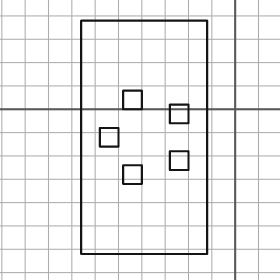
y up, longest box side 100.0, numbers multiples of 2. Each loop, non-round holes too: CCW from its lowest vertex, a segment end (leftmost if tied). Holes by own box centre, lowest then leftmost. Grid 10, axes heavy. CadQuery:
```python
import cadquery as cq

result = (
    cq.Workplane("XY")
    .moveTo(-66.0, -62.0)
    .lineTo(-12.0, -62.0)
    .lineTo(-12.0, 38.0)
    .lineTo(-66.0, 38.0)
    .close()
    .moveTo(-48.0, -32.0)
    .lineTo(-40.0, -32.0)
    .lineTo(-40.0, -24.0)
    .lineTo(-48.0, -24.0)
    .close()
    .moveTo(-28.0, -26.0)
    .lineTo(-20.0, -26.0)
    .lineTo(-20.0, -18.0)
    .lineTo(-28.0, -18.0)
    .close()
    .moveTo(-58.0, -16.0)
    .lineTo(-50.0, -16.0)
    .lineTo(-50.0, -8.0)
    .lineTo(-58.0, -8.0)
    .close()
    .moveTo(-28.0, -6.0)
    .lineTo(-20.0, -6.0)
    .lineTo(-20.0, 2.0)
    .lineTo(-28.0, 2.0)
    .close()
    .moveTo(-48.0, 0.0)
    .lineTo(-40.0, 0.0)
    .lineTo(-40.0, 8.0)
    .lineTo(-48.0, 8.0)
    .close()
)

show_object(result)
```